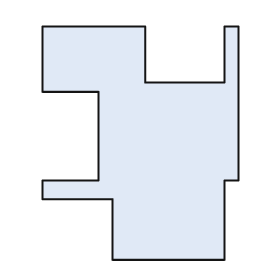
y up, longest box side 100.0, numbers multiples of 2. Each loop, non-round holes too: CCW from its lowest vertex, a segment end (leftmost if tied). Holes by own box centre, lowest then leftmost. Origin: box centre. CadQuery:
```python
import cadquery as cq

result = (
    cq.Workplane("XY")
    .moveTo(-12.0, -50.0)
    .lineTo(36.0, -50.0)
    .lineTo(36.0, -16.0)
    .lineTo(42.0, -16.0)
    .lineTo(42.0, 50.0)
    .lineTo(36.0, 50.0)
    .lineTo(36.0, 26.0)
    .lineTo(2.0, 26.0)
    .lineTo(2.0, 50.0)
    .lineTo(-42.0, 50.0)
    .lineTo(-42.0, 22.0)
    .lineTo(-18.0, 22.0)
    .lineTo(-18.0, -16.0)
    .lineTo(-42.0, -16.0)
    .lineTo(-42.0, -24.0)
    .lineTo(-12.0, -24.0)
    .close()
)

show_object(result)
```